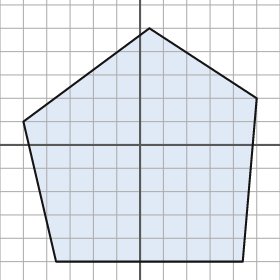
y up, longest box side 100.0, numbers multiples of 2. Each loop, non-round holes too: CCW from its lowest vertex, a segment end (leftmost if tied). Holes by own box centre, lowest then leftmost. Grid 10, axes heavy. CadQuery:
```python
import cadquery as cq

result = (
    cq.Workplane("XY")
    .moveTo(-36.0, -50.0)
    .lineTo(44.0, -50.0)
    .lineTo(50.0, 20.0)
    .lineTo(4.0, 50.0)
    .lineTo(-50.0, 10.0)
    .close()
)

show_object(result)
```